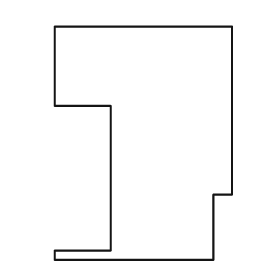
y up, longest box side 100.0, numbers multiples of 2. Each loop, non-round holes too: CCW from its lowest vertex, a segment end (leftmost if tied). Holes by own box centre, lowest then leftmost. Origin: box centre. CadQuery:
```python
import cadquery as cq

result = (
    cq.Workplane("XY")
    .moveTo(-38.0, -50.0)
    .lineTo(30.0, -50.0)
    .lineTo(30.0, -22.0)
    .lineTo(38.0, -22.0)
    .lineTo(38.0, 50.0)
    .lineTo(-38.0, 50.0)
    .lineTo(-38.0, 16.0)
    .lineTo(-14.0, 16.0)
    .lineTo(-14.0, -46.0)
    .lineTo(-38.0, -46.0)
    .close()
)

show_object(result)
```